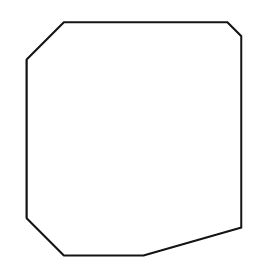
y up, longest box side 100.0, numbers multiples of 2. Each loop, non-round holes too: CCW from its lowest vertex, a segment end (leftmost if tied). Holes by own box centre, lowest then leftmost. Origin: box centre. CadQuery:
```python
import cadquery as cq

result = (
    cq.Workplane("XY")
    .moveTo(-30.0, -50.0)
    .lineTo(4.0, -50.0)
    .lineTo(46.0, -38.0)
    .lineTo(46.0, 44.0)
    .lineTo(40.0, 50.0)
    .lineTo(-30.0, 50.0)
    .lineTo(-46.0, 34.0)
    .lineTo(-46.0, -34.0)
    .close()
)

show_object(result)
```